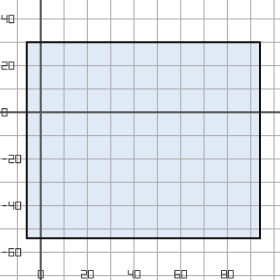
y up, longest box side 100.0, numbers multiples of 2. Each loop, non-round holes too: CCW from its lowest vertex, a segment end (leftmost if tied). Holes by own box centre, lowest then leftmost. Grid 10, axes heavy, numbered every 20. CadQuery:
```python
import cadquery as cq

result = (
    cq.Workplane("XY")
    .moveTo(-6.0, -54.0)
    .lineTo(94.0, -54.0)
    .lineTo(94.0, 30.0)
    .lineTo(-6.0, 30.0)
    .close()
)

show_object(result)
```